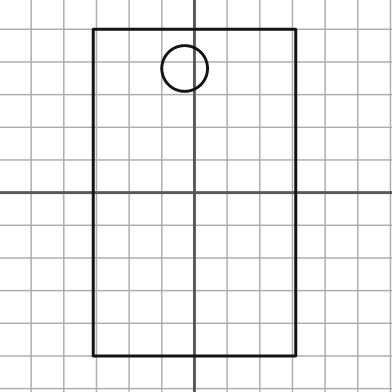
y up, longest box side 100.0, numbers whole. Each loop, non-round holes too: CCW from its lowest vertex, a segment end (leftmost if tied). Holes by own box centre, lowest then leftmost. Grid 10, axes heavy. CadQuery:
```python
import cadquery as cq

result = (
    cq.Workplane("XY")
    .moveTo(-31.0, -50.0)
    .lineTo(31.0, -50.0)
    .lineTo(31.0, 50.0)
    .lineTo(-31.0, 50.0)
    .close()
    .moveTo(-3.0, 38.0)
    .circle(7.0)
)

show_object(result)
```